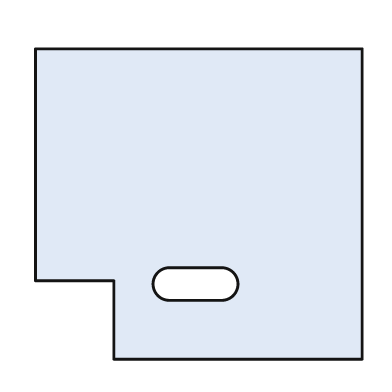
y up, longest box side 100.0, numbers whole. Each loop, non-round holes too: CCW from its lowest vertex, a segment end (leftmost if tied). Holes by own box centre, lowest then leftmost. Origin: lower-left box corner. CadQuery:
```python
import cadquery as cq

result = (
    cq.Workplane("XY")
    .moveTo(24.0, 0.0)
    .lineTo(100.0, 0.0)
    .lineTo(100.0, 95.0)
    .lineTo(0.0, 95.0)
    .lineTo(0.0, 24.0)
    .lineTo(24.0, 24.0)
    .close()
    .moveTo(41.0, 18.0)
    .lineTo(57.0, 18.0)
    .threePointArc((62.0, 23.0), (57.0, 28.0))
    .lineTo(41.0, 28.0)
    .threePointArc((36.0, 23.0), (41.0, 18.0))
    .close()
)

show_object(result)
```